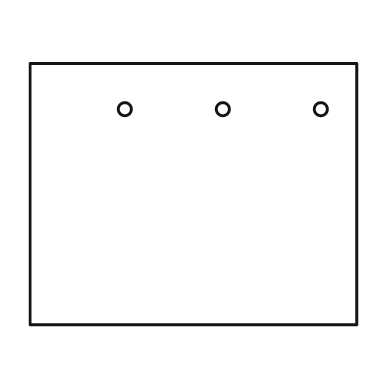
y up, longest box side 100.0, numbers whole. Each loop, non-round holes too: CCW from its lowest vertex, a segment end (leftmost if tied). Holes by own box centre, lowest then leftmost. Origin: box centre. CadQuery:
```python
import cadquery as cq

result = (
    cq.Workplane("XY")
    .moveTo(-50.0, -40.0)
    .lineTo(50.0, -40.0)
    .lineTo(50.0, 40.0)
    .lineTo(-50.0, 40.0)
    .close()
    .moveTo(-21.0, 26.0)
    .circle(2.0)
    .moveTo(9.0, 26.0)
    .circle(2.0)
    .moveTo(39.0, 26.0)
    .circle(2.0)
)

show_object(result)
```